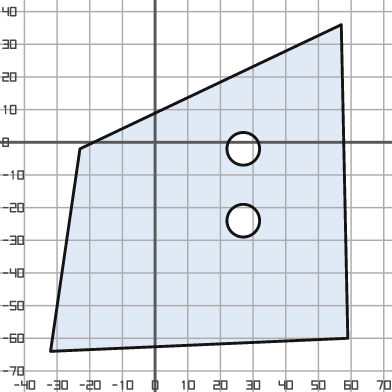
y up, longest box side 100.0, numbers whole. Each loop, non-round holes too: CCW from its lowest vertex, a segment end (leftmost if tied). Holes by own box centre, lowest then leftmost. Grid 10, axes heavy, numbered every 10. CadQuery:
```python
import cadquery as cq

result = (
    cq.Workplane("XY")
    .moveTo(-32.0, -64.0)
    .lineTo(59.0, -60.0)
    .lineTo(57.0, 36.0)
    .lineTo(-23.0, -2.0)
    .close()
    .moveTo(27.0, -24.0)
    .circle(5.0)
    .moveTo(27.0, -2.0)
    .circle(5.0)
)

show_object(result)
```